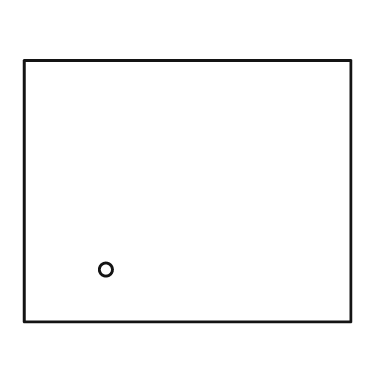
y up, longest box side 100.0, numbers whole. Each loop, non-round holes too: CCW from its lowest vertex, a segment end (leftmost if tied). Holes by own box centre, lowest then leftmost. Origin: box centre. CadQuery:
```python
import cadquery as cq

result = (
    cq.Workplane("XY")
    .moveTo(-50.0, -40.0)
    .lineTo(50.0, -40.0)
    .lineTo(50.0, 40.0)
    .lineTo(-50.0, 40.0)
    .close()
    .moveTo(-25.0, -24.0)
    .circle(2.0)
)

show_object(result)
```